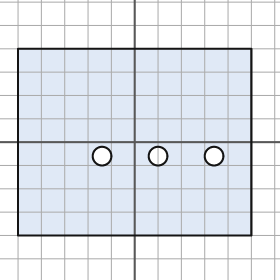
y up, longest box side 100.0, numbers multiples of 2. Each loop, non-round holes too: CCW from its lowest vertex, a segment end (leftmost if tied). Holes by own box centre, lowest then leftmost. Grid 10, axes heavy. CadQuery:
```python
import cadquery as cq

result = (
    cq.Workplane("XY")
    .moveTo(-50.0, -40.0)
    .lineTo(50.0, -40.0)
    .lineTo(50.0, 40.0)
    .lineTo(-50.0, 40.0)
    .close()
    .moveTo(-14.0, -6.0)
    .circle(4.0)
    .moveTo(10.0, -6.0)
    .circle(4.0)
    .moveTo(34.0, -6.0)
    .circle(4.0)
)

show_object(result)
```